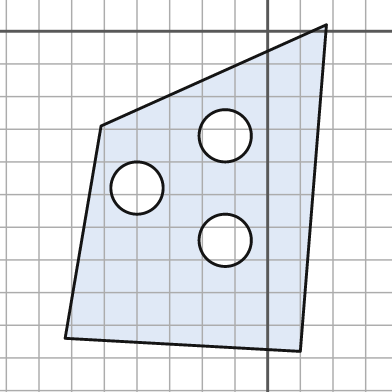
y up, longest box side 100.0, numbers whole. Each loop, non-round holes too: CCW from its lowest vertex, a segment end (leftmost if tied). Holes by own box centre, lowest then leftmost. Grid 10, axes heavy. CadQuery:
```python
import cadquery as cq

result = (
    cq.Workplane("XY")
    .moveTo(10.0, -98.0)
    .lineTo(18.0, 2.0)
    .lineTo(-51.0, -29.0)
    .lineTo(-62.0, -94.0)
    .close()
    .moveTo(-13.0, -64.0)
    .circle(8.0)
    .moveTo(-40.0, -48.0)
    .circle(8.0)
    .moveTo(-13.0, -32.0)
    .circle(8.0)
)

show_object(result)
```